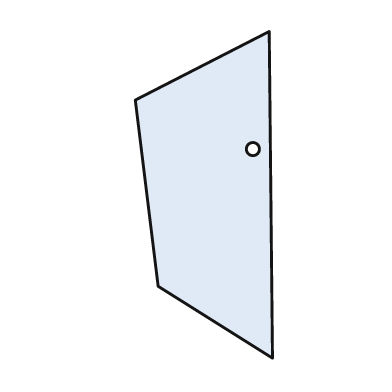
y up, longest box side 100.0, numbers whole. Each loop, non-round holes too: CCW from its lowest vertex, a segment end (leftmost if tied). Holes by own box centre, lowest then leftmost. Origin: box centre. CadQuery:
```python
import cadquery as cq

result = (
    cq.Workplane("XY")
    .moveTo(21.0, -50.0)
    .lineTo(20.0, 50.0)
    .lineTo(-21.0, 29.0)
    .lineTo(-14.0, -28.0)
    .close()
    .moveTo(15.0, 14.0)
    .circle(2.0)
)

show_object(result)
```